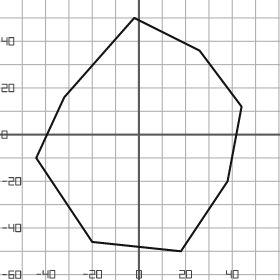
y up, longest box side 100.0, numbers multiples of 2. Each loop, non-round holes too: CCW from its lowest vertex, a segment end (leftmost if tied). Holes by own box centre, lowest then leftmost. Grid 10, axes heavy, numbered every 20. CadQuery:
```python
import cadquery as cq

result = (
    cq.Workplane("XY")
    .moveTo(18.0, -50.0)
    .lineTo(38.0, -20.0)
    .lineTo(44.0, 12.0)
    .lineTo(26.0, 36.0)
    .lineTo(-2.0, 50.0)
    .lineTo(-32.0, 16.0)
    .lineTo(-44.0, -10.0)
    .lineTo(-20.0, -46.0)
    .close()
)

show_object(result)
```